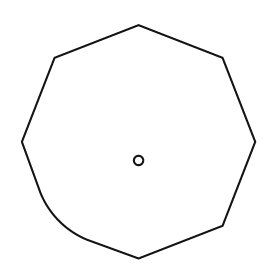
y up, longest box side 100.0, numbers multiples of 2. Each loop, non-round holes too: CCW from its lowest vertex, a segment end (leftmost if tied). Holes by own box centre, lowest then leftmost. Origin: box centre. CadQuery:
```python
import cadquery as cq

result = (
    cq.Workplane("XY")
    .moveTo(0.0, -50.0)
    .lineTo(36.0, -36.0)
    .lineTo(50.0, 0.0)
    .lineTo(36.0, 36.0)
    .lineTo(0.0, 50.0)
    .lineTo(-36.0, 36.0)
    .lineTo(-50.0, 0.0)
    .lineTo(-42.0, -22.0)
    .threePointArc((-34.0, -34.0), (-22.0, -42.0))
    .close()
    .moveTo(0.0, -8.0)
    .circle(2.0)
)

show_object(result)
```